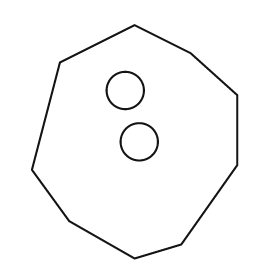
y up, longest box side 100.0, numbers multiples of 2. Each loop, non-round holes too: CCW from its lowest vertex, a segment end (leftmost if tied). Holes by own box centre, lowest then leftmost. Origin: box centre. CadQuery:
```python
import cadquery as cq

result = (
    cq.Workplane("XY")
    .moveTo(0.0, -50.0)
    .lineTo(20.0, -44.0)
    .lineTo(44.0, -10.0)
    .lineTo(44.0, 20.0)
    .lineTo(24.0, 38.0)
    .lineTo(0.0, 50.0)
    .lineTo(-32.0, 34.0)
    .lineTo(-44.0, -12.0)
    .lineTo(-28.0, -34.0)
    .close()
    .moveTo(2.0, 0.0)
    .circle(8.0)
    .moveTo(-4.0, 22.0)
    .circle(8.0)
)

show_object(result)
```